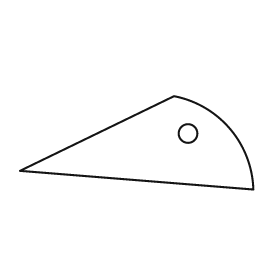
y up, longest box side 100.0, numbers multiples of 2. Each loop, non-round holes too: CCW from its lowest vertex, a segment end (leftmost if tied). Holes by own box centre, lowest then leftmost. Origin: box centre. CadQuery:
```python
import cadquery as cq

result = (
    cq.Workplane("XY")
    .moveTo(50.0, -20.0)
    .threePointArc((40.0, 6.0), (16.0, 20.0))
    .lineTo(-50.0, -12.0)
    .close()
    .moveTo(22.0, 4.0)
    .circle(4.0)
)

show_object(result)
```